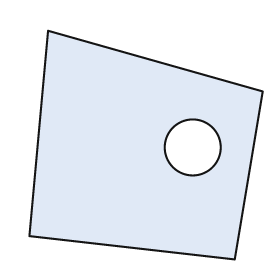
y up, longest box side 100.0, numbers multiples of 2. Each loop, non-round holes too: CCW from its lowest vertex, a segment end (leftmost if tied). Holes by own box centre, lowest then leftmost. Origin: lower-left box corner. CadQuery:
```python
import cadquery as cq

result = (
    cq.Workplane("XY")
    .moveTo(88.0, 0.0)
    .lineTo(100.0, 72.0)
    .lineTo(8.0, 98.0)
    .lineTo(0.0, 10.0)
    .close()
    .moveTo(70.0, 48.0)
    .circle(12.0)
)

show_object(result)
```